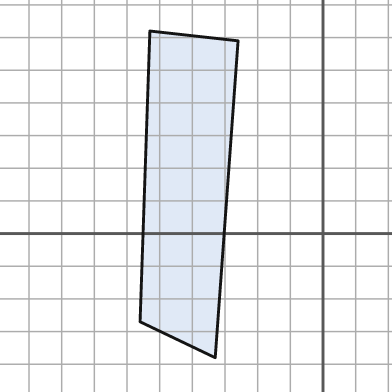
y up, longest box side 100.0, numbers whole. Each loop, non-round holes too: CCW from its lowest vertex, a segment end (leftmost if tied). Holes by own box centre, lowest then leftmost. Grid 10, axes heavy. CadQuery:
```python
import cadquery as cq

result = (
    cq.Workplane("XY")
    .moveTo(-33.0, -38.0)
    .lineTo(-26.0, 59.0)
    .lineTo(-53.0, 62.0)
    .lineTo(-56.0, -27.0)
    .close()
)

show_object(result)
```